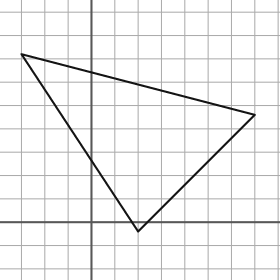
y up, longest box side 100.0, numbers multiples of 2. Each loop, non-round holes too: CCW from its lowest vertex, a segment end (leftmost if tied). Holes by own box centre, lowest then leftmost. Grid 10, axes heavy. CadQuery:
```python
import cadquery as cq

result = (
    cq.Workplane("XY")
    .moveTo(20.0, -4.0)
    .lineTo(70.0, 46.0)
    .lineTo(-30.0, 72.0)
    .close()
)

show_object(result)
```